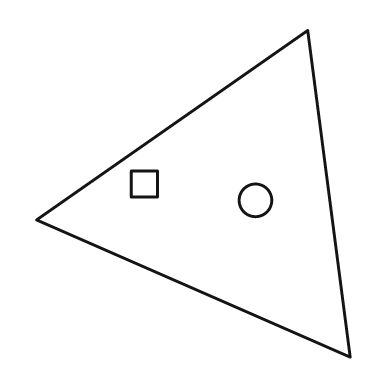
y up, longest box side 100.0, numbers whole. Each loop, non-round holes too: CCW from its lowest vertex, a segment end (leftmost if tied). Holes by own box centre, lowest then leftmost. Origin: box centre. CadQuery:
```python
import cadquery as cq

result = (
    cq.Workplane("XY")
    .moveTo(48.0, -50.0)
    .lineTo(35.0, 50.0)
    .lineTo(-48.0, -8.0)
    .close()
    .moveTo(19.0, -2.0)
    .circle(5.0)
    .moveTo(-19.0, -1.0)
    .lineTo(-11.0, -1.0)
    .lineTo(-11.0, 7.0)
    .lineTo(-19.0, 7.0)
    .close()
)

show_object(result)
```